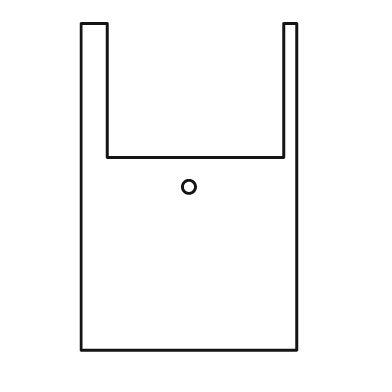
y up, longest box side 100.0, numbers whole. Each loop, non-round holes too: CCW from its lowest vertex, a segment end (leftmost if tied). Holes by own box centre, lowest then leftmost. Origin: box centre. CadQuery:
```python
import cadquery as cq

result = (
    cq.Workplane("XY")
    .moveTo(-33.0, -50.0)
    .lineTo(33.0, -50.0)
    .lineTo(33.0, 50.0)
    .lineTo(29.0, 50.0)
    .lineTo(29.0, 9.0)
    .lineTo(-25.0, 9.0)
    .lineTo(-25.0, 50.0)
    .lineTo(-33.0, 50.0)
    .close()
    .moveTo(0.0, 0.0)
    .circle(2.0)
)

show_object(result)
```